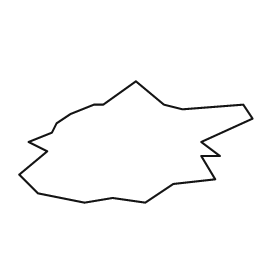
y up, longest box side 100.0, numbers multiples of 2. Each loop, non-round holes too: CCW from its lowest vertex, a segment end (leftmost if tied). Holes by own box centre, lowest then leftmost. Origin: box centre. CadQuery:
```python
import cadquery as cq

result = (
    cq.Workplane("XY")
    .moveTo(-22.0, -26.0)
    .lineTo(-10.0, -24.0)
    .lineTo(4.0, -26.0)
    .lineTo(16.0, -18.0)
    .lineTo(34.0, -16.0)
    .lineTo(28.0, -6.0)
    .lineTo(36.0, -6.0)
    .lineTo(28.0, 0.0)
    .lineTo(50.0, 10.0)
    .lineTo(46.0, 16.0)
    .lineTo(20.0, 14.0)
    .lineTo(12.0, 16.0)
    .lineTo(0.0, 26.0)
    .lineTo(-14.0, 16.0)
    .lineTo(-18.0, 16.0)
    .lineTo(-28.0, 12.0)
    .lineTo(-34.0, 8.0)
    .lineTo(-36.0, 4.0)
    .lineTo(-46.0, 0.0)
    .lineTo(-38.0, -4.0)
    .lineTo(-50.0, -14.0)
    .lineTo(-42.0, -22.0)
    .close()
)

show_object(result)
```